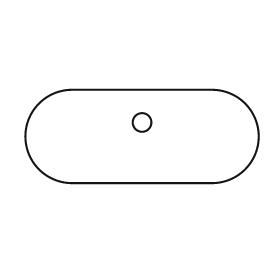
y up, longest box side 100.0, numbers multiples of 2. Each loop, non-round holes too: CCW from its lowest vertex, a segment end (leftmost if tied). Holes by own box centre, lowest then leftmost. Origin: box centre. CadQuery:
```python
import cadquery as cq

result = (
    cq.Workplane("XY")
    .moveTo(-30.0, -20.0)
    .lineTo(30.0, -20.0)
    .threePointArc((50.0, 0.0), (30.0, 20.0))
    .lineTo(-30.0, 20.0)
    .threePointArc((-50.0, 0.0), (-30.0, -20.0))
    .close()
    .moveTo(0.0, 6.0)
    .circle(4.0)
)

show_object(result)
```